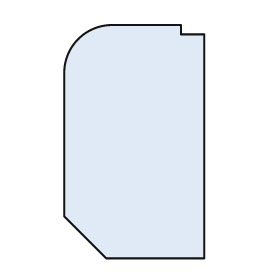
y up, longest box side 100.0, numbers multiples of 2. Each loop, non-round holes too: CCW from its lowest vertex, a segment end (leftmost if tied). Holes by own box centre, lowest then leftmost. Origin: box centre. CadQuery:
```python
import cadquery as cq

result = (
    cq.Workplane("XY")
    .moveTo(-12.0, -50.0)
    .lineTo(30.0, -50.0)
    .lineTo(30.0, 46.0)
    .lineTo(20.0, 46.0)
    .lineTo(20.0, 50.0)
    .lineTo(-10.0, 50.0)
    .threePointArc((-24.0, 44.0), (-30.0, 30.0))
    .lineTo(-30.0, -32.0)
    .close()
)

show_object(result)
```